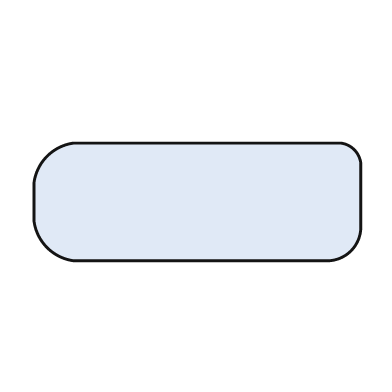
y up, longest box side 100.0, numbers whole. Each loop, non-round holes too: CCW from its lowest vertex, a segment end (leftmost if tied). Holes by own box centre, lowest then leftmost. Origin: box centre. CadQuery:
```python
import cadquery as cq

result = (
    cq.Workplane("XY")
    .moveTo(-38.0, -18.0)
    .lineTo(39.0, -18.0)
    .threePointArc((47.0, -15.0), (50.0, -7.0))
    .lineTo(50.0, 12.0)
    .threePointArc((48.0, 16.0), (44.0, 18.0))
    .lineTo(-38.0, 18.0)
    .threePointArc((-46.0, 14.0), (-50.0, 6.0))
    .lineTo(-50.0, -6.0)
    .threePointArc((-46.0, -14.0), (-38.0, -18.0))
    .close()
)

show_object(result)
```